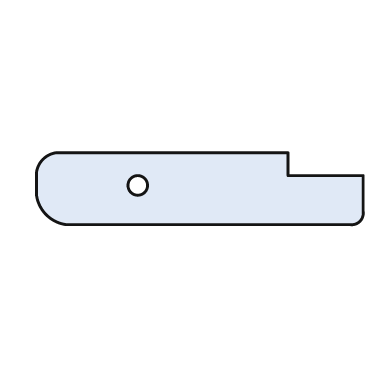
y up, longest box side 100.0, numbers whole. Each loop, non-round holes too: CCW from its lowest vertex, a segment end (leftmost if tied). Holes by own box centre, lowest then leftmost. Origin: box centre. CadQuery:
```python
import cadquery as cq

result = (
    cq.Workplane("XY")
    .moveTo(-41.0, -11.0)
    .lineTo(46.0, -11.0)
    .threePointArc((49.0, -10.0), (50.0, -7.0))
    .lineTo(50.0, 4.0)
    .lineTo(27.0, 4.0)
    .lineTo(27.0, 11.0)
    .lineTo(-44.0, 11.0)
    .threePointArc((-48.0, 9.0), (-50.0, 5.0))
    .lineTo(-50.0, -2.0)
    .threePointArc((-47.0, -8.0), (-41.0, -11.0))
    .close()
    .moveTo(-19.0, 1.0)
    .circle(3.0)
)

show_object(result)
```